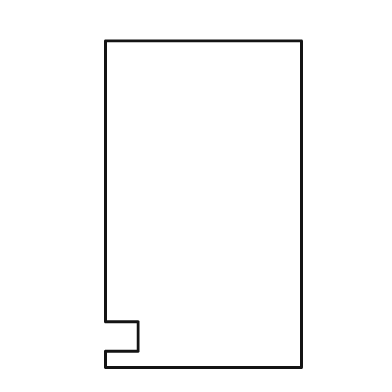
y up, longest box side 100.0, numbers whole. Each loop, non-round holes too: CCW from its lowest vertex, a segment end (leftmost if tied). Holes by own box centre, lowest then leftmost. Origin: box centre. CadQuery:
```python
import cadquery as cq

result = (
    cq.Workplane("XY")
    .moveTo(-30.0, -50.0)
    .lineTo(30.0, -50.0)
    .lineTo(30.0, 50.0)
    .lineTo(-30.0, 50.0)
    .lineTo(-30.0, -36.0)
    .lineTo(-20.0, -36.0)
    .lineTo(-20.0, -45.0)
    .lineTo(-30.0, -45.0)
    .close()
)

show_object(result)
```